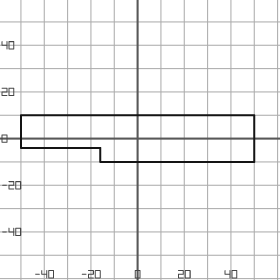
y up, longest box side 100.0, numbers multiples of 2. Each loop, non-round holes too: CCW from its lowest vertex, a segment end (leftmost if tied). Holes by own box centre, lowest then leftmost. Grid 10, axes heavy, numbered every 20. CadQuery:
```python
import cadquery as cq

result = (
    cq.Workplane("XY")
    .moveTo(-16.0, -10.0)
    .lineTo(50.0, -10.0)
    .lineTo(50.0, 10.0)
    .lineTo(-50.0, 10.0)
    .lineTo(-50.0, -4.0)
    .lineTo(-16.0, -4.0)
    .close()
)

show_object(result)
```